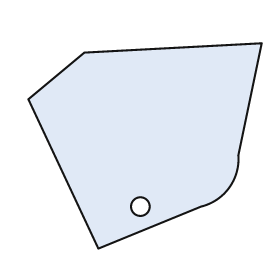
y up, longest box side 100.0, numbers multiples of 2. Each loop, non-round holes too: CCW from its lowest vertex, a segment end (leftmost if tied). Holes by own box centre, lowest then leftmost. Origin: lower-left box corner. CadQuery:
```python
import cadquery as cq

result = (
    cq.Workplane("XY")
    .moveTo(30.0, 0.0)
    .lineTo(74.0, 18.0)
    .threePointArc((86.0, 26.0), (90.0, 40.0))
    .lineTo(100.0, 88.0)
    .lineTo(24.0, 84.0)
    .lineTo(0.0, 64.0)
    .close()
    .moveTo(48.0, 18.0)
    .circle(4.0)
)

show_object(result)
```